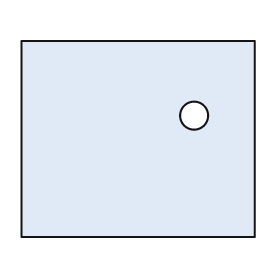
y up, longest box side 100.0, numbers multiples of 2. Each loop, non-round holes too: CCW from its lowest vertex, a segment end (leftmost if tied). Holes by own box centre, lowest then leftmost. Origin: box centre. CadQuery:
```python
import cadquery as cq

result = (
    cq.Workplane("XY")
    .moveTo(-50.0, -42.0)
    .lineTo(50.0, -42.0)
    .lineTo(50.0, 42.0)
    .lineTo(-50.0, 42.0)
    .close()
    .moveTo(24.0, 10.0)
    .circle(6.0)
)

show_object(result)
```